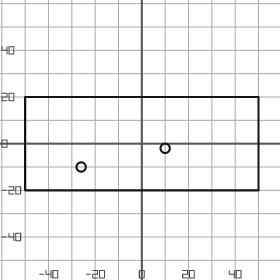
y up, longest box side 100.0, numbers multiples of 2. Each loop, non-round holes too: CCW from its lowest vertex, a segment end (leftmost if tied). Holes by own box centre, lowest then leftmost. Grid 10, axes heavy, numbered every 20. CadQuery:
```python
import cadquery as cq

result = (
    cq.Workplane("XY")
    .moveTo(-50.0, -20.0)
    .lineTo(50.0, -20.0)
    .lineTo(50.0, 20.0)
    .lineTo(-50.0, 20.0)
    .close()
    .moveTo(-26.0, -10.0)
    .circle(2.0)
    .moveTo(10.0, -2.0)
    .circle(2.0)
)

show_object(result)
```